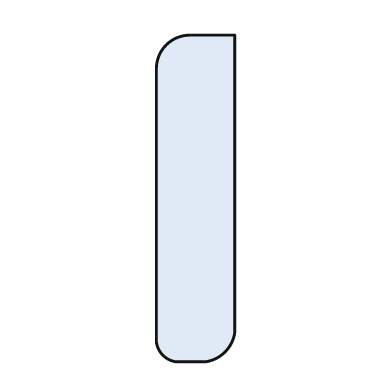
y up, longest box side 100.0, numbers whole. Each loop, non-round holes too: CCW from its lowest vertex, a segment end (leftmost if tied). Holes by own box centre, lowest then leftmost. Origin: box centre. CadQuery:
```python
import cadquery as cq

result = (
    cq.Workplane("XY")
    .moveTo(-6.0, -50.0)
    .lineTo(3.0, -50.0)
    .threePointArc((9.0, -47.0), (12.0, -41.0))
    .lineTo(12.0, 50.0)
    .lineTo(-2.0, 50.0)
    .threePointArc((-9.0, 47.0), (-12.0, 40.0))
    .lineTo(-12.0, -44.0)
    .threePointArc((-10.0, -48.0), (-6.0, -50.0))
    .close()
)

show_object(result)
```